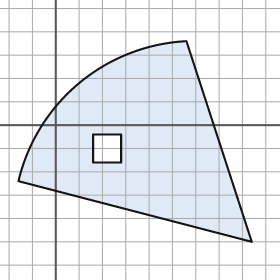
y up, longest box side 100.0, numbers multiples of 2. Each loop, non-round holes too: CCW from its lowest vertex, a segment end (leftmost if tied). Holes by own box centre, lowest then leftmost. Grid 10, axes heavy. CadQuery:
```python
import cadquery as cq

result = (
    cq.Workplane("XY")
    .moveTo(84.0, -50.0)
    .lineTo(56.0, 36.0)
    .threePointArc((10.0, 18.0), (-16.0, -24.0))
    .close()
    .moveTo(16.0, -16.0)
    .lineTo(28.0, -16.0)
    .lineTo(28.0, -4.0)
    .lineTo(16.0, -4.0)
    .close()
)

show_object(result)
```